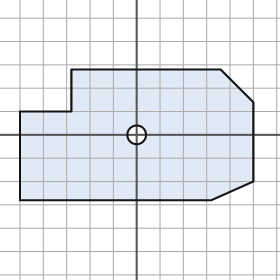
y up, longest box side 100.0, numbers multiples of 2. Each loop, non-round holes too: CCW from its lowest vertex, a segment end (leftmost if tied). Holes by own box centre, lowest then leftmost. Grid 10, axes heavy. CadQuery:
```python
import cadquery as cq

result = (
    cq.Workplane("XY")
    .moveTo(-50.0, -28.0)
    .lineTo(32.0, -28.0)
    .lineTo(50.0, -20.0)
    .lineTo(50.0, 14.0)
    .lineTo(36.0, 28.0)
    .lineTo(-28.0, 28.0)
    .lineTo(-28.0, 10.0)
    .lineTo(-50.0, 10.0)
    .close()
    .moveTo(0.0, 0.0)
    .circle(4.0)
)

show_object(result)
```